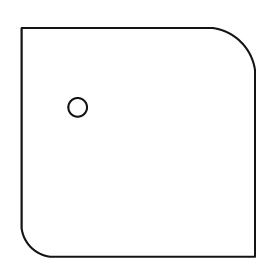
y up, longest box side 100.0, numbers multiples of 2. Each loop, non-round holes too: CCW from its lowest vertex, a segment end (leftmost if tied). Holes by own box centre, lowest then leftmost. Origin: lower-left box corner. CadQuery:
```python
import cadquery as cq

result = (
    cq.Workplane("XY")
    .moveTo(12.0, 0.0)
    .lineTo(100.0, 0.0)
    .lineTo(100.0, 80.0)
    .threePointArc((94.0, 92.0), (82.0, 98.0))
    .lineTo(0.0, 98.0)
    .lineTo(0.0, 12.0)
    .threePointArc((4.0, 4.0), (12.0, 0.0))
    .close()
    .moveTo(24.0, 64.0)
    .circle(4.0)
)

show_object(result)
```